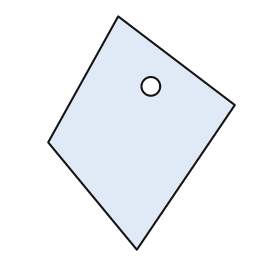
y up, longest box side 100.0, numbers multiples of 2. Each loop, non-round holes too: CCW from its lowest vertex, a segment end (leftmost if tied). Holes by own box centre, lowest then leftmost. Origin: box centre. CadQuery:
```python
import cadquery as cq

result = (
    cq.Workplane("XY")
    .moveTo(-2.0, -50.0)
    .lineTo(40.0, 12.0)
    .lineTo(-10.0, 50.0)
    .lineTo(-40.0, -4.0)
    .close()
    .moveTo(4.0, 20.0)
    .circle(4.0)
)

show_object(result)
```